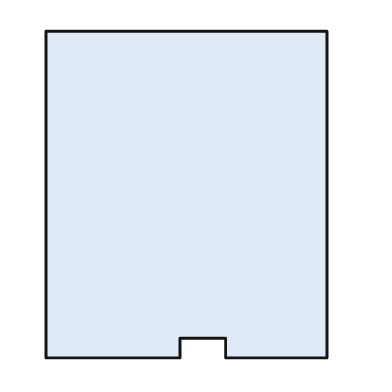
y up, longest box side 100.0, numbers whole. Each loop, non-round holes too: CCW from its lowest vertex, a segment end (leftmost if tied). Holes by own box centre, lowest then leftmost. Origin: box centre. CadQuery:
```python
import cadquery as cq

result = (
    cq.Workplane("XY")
    .moveTo(-43.0, -50.0)
    .lineTo(-2.0, -50.0)
    .lineTo(-2.0, -44.0)
    .lineTo(12.0, -44.0)
    .lineTo(12.0, -50.0)
    .lineTo(43.0, -50.0)
    .lineTo(43.0, 50.0)
    .lineTo(-43.0, 50.0)
    .close()
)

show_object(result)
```